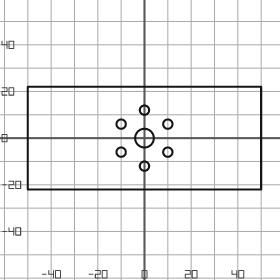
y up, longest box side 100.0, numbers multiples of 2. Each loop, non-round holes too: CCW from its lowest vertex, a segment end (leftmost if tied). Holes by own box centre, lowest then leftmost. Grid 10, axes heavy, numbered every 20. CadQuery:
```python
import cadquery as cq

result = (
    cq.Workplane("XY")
    .moveTo(-50.0, -22.0)
    .lineTo(50.0, -22.0)
    .lineTo(50.0, 22.0)
    .lineTo(-50.0, 22.0)
    .close()
    .moveTo(0.0, -12.0)
    .circle(2.0)
    .moveTo(-10.0, -6.0)
    .circle(2.0)
    .moveTo(10.0, -6.0)
    .circle(2.0)
    .moveTo(0.0, 0.0)
    .circle(4.0)
    .moveTo(-10.0, 6.0)
    .circle(2.0)
    .moveTo(10.0, 6.0)
    .circle(2.0)
    .moveTo(0.0, 12.0)
    .circle(2.0)
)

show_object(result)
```